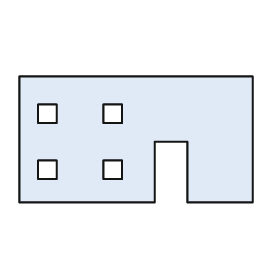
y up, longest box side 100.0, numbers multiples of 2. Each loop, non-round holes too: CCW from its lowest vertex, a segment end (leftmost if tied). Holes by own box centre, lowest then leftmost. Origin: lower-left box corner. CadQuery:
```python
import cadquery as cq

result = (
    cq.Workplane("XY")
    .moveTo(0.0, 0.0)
    .lineTo(58.0, 0.0)
    .lineTo(58.0, 26.0)
    .lineTo(72.0, 26.0)
    .lineTo(72.0, 0.0)
    .lineTo(100.0, 0.0)
    .lineTo(100.0, 54.0)
    .lineTo(0.0, 54.0)
    .close()
    .moveTo(8.0, 10.0)
    .lineTo(16.0, 10.0)
    .lineTo(16.0, 18.0)
    .lineTo(8.0, 18.0)
    .close()
    .moveTo(36.0, 10.0)
    .lineTo(44.0, 10.0)
    .lineTo(44.0, 18.0)
    .lineTo(36.0, 18.0)
    .close()
    .moveTo(8.0, 34.0)
    .lineTo(16.0, 34.0)
    .lineTo(16.0, 42.0)
    .lineTo(8.0, 42.0)
    .close()
    .moveTo(36.0, 34.0)
    .lineTo(44.0, 34.0)
    .lineTo(44.0, 42.0)
    .lineTo(36.0, 42.0)
    .close()
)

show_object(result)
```